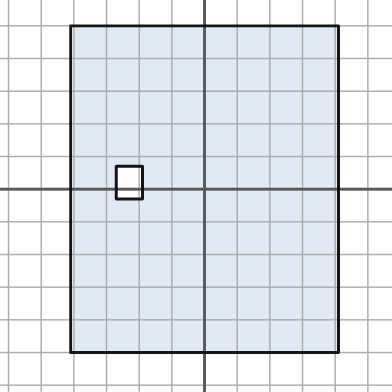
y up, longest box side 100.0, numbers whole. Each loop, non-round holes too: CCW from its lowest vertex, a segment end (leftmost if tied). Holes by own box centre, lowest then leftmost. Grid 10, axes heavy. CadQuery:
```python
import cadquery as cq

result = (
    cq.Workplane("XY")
    .moveTo(-41.0, -50.0)
    .lineTo(41.0, -50.0)
    .lineTo(41.0, 50.0)
    .lineTo(-41.0, 50.0)
    .close()
    .moveTo(-27.0, -3.0)
    .lineTo(-19.0, -3.0)
    .lineTo(-19.0, 7.0)
    .lineTo(-27.0, 7.0)
    .close()
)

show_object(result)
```